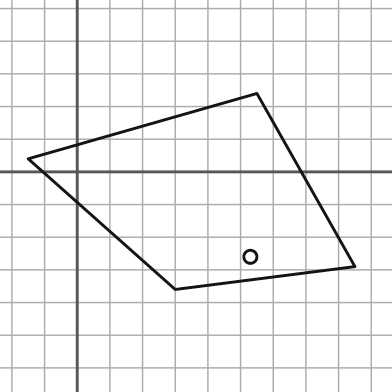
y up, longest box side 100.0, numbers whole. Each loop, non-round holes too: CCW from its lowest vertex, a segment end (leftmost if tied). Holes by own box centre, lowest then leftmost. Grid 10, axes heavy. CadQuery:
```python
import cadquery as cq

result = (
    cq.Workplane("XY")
    .moveTo(30.0, -36.0)
    .lineTo(85.0, -29.0)
    .lineTo(55.0, 24.0)
    .lineTo(-15.0, 4.0)
    .close()
    .moveTo(53.0, -26.0)
    .circle(2.0)
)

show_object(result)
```